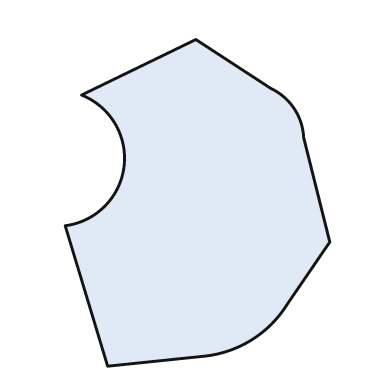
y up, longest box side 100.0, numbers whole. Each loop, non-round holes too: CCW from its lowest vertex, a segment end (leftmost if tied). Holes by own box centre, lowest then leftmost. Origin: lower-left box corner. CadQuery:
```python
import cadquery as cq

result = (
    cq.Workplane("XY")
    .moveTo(13.0, 0.0)
    .lineTo(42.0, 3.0)
    .threePointArc((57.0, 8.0), (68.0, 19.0))
    .lineTo(81.0, 38.0)
    .lineTo(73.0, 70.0)
    .threePointArc((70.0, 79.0), (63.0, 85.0))
    .lineTo(40.0, 100.0)
    .lineTo(5.0, 83.0)
    .threePointArc((18.0, 61.0), (0.0, 43.0))
    .close()
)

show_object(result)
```